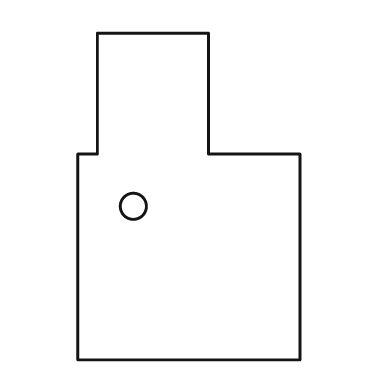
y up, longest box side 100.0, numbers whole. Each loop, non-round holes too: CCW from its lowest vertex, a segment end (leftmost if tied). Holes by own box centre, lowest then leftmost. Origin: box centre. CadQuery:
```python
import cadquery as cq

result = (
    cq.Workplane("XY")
    .moveTo(-34.0, -50.0)
    .lineTo(34.0, -50.0)
    .lineTo(34.0, 13.0)
    .lineTo(6.0, 13.0)
    .lineTo(6.0, 50.0)
    .lineTo(-28.0, 50.0)
    .lineTo(-28.0, 13.0)
    .lineTo(-34.0, 13.0)
    .close()
    .moveTo(-17.0, -3.0)
    .circle(4.0)
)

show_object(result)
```